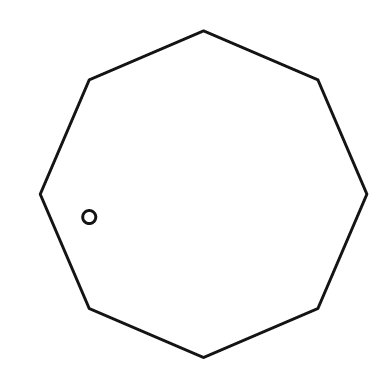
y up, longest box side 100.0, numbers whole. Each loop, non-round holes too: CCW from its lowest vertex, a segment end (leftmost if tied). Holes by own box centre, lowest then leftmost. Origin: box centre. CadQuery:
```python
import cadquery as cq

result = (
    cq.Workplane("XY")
    .moveTo(0.0, -50.0)
    .lineTo(35.0, -35.0)
    .lineTo(50.0, 0.0)
    .lineTo(35.0, 35.0)
    .lineTo(0.0, 50.0)
    .lineTo(-35.0, 35.0)
    .lineTo(-50.0, 0.0)
    .lineTo(-35.0, -35.0)
    .close()
    .moveTo(-35.0, -7.0)
    .circle(2.0)
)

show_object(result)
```